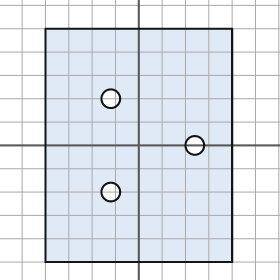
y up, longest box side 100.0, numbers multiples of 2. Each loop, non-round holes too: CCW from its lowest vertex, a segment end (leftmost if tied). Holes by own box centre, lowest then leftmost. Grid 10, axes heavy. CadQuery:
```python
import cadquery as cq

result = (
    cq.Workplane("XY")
    .moveTo(-40.0, -50.0)
    .lineTo(40.0, -50.0)
    .lineTo(40.0, 50.0)
    .lineTo(-40.0, 50.0)
    .close()
    .moveTo(-12.0, -20.0)
    .circle(4.0)
    .moveTo(24.0, 0.0)
    .circle(4.0)
    .moveTo(-12.0, 20.0)
    .circle(4.0)
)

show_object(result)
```